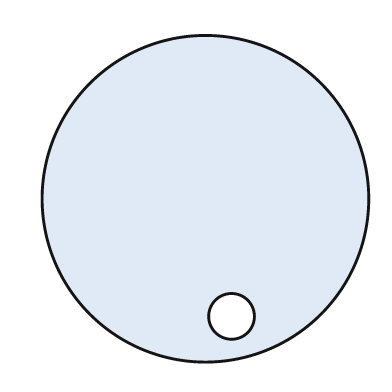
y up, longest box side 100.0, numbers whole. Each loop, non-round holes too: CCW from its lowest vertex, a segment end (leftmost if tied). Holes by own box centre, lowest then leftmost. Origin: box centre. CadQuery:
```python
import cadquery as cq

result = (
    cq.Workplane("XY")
    .moveTo(0.0, 0.0)
    .circle(50.0)
    .moveTo(8.0, -36.0)
    .circle(7.0)
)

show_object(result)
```